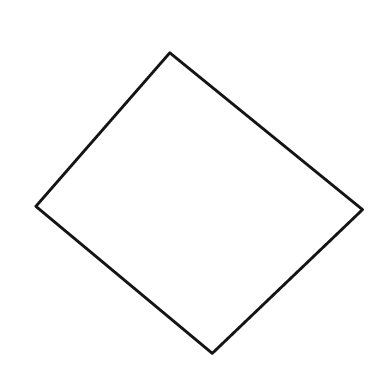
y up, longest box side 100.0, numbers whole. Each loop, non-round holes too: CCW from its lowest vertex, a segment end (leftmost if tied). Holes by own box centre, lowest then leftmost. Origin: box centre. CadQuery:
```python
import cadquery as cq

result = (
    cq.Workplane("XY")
    .moveTo(4.0, -46.0)
    .lineTo(50.0, -2.0)
    .lineTo(-9.0, 46.0)
    .lineTo(-50.0, -1.0)
    .close()
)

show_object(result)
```